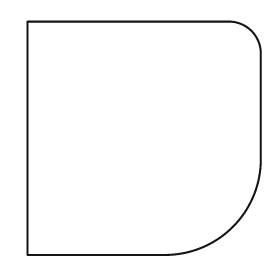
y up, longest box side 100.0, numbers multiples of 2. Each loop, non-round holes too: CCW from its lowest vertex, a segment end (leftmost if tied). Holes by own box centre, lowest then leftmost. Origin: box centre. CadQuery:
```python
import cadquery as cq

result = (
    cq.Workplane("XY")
    .moveTo(-50.0, -50.0)
    .lineTo(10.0, -50.0)
    .threePointArc((38.0, -38.0), (50.0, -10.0))
    .lineTo(50.0, 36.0)
    .threePointArc((46.0, 46.0), (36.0, 50.0))
    .lineTo(-50.0, 50.0)
    .close()
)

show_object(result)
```